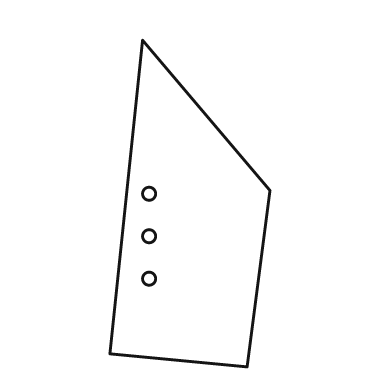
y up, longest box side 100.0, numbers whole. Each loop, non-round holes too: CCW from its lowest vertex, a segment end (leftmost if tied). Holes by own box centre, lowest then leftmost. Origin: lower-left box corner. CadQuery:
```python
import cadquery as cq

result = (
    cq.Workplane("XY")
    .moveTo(42.0, 0.0)
    .lineTo(49.0, 54.0)
    .lineTo(10.0, 100.0)
    .lineTo(0.0, 4.0)
    .close()
    .moveTo(12.0, 27.0)
    .circle(2.0)
    .moveTo(12.0, 40.0)
    .circle(2.0)
    .moveTo(12.0, 53.0)
    .circle(2.0)
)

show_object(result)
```